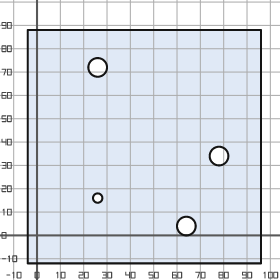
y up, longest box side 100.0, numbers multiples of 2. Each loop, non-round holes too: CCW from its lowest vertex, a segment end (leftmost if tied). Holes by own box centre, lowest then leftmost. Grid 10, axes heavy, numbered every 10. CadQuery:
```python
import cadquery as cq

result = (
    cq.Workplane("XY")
    .moveTo(-4.0, -12.0)
    .lineTo(96.0, -12.0)
    .lineTo(96.0, 88.0)
    .lineTo(-4.0, 88.0)
    .close()
    .moveTo(64.0, 4.0)
    .circle(4.0)
    .moveTo(26.0, 16.0)
    .circle(2.0)
    .moveTo(78.0, 34.0)
    .circle(4.0)
    .moveTo(26.0, 72.0)
    .circle(4.0)
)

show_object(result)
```